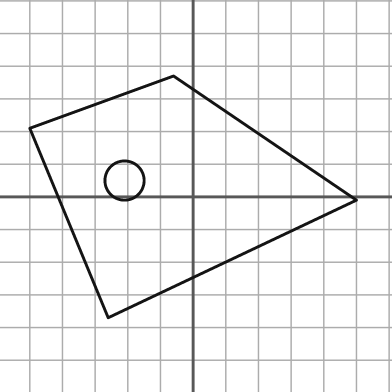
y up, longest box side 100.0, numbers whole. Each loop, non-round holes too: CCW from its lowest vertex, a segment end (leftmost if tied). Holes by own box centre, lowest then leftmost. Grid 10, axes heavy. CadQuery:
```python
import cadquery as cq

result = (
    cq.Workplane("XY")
    .moveTo(-26.0, -37.0)
    .lineTo(50.0, -1.0)
    .lineTo(-6.0, 37.0)
    .lineTo(-50.0, 21.0)
    .close()
    .moveTo(-21.0, 5.0)
    .circle(6.0)
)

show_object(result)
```